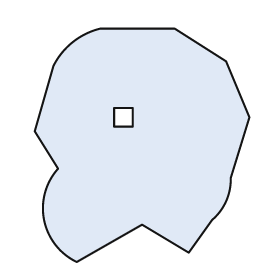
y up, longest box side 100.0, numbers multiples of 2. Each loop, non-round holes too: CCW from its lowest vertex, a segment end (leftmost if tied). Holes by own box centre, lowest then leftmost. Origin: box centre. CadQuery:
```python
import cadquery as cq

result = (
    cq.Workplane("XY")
    .moveTo(-28.0, -50.0)
    .lineTo(0.0, -34.0)
    .lineTo(20.0, -46.0)
    .lineTo(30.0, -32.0)
    .threePointArc((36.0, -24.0), (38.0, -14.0))
    .lineTo(46.0, 12.0)
    .lineTo(36.0, 36.0)
    .lineTo(14.0, 50.0)
    .lineTo(-18.0, 50.0)
    .threePointArc((-30.0, 44.0), (-38.0, 34.0))
    .lineTo(-46.0, 6.0)
    .lineTo(-36.0, -10.0)
    .threePointArc((-42.0, -32.0), (-28.0, -50.0))
    .close()
    .moveTo(-12.0, 8.0)
    .lineTo(-4.0, 8.0)
    .lineTo(-4.0, 16.0)
    .lineTo(-12.0, 16.0)
    .close()
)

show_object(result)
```